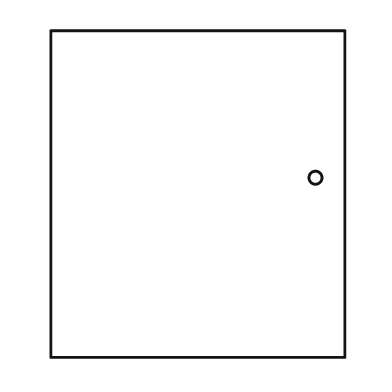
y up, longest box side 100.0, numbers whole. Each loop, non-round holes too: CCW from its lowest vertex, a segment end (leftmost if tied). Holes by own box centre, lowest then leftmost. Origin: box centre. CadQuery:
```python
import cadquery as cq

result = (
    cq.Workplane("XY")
    .moveTo(-45.0, -50.0)
    .lineTo(45.0, -50.0)
    .lineTo(45.0, 50.0)
    .lineTo(-45.0, 50.0)
    .close()
    .moveTo(36.0, 5.0)
    .circle(2.0)
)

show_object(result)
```